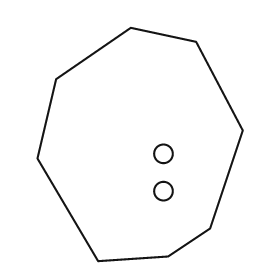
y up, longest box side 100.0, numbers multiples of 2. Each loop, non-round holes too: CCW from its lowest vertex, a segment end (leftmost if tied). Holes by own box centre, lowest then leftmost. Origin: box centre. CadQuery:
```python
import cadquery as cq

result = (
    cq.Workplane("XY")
    .moveTo(-18.0, -50.0)
    .lineTo(12.0, -48.0)
    .lineTo(30.0, -36.0)
    .lineTo(44.0, 6.0)
    .lineTo(24.0, 44.0)
    .lineTo(-4.0, 50.0)
    .lineTo(-36.0, 28.0)
    .lineTo(-44.0, -6.0)
    .close()
    .moveTo(10.0, -20.0)
    .circle(4.0)
    .moveTo(10.0, -4.0)
    .circle(4.0)
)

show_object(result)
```